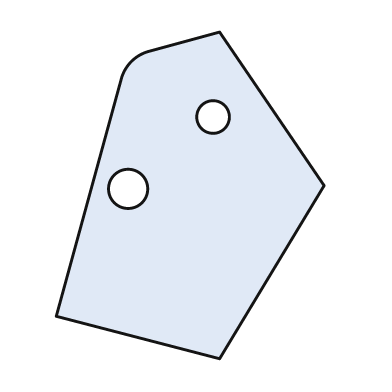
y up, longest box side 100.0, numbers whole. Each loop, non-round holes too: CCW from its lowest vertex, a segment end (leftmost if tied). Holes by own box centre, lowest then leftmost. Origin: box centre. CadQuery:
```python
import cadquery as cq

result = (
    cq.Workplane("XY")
    .moveTo(9.0, -50.0)
    .lineTo(41.0, 3.0)
    .lineTo(9.0, 50.0)
    .lineTo(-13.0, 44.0)
    .threePointArc((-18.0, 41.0), (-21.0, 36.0))
    .lineTo(-41.0, -37.0)
    .close()
    .moveTo(-19.0, 2.0)
    .circle(6.0)
    .moveTo(7.0, 24.0)
    .circle(5.0)
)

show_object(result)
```